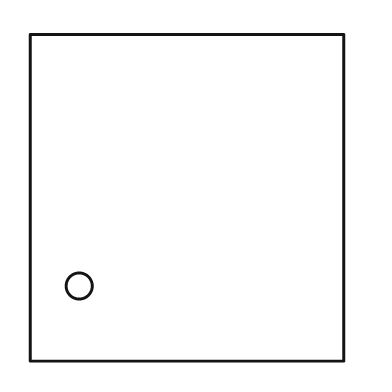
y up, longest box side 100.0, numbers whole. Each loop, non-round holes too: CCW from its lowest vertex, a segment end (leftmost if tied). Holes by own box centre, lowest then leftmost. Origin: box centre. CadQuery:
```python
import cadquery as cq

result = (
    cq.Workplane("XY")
    .moveTo(-48.0, -50.0)
    .lineTo(48.0, -50.0)
    .lineTo(48.0, 50.0)
    .lineTo(-48.0, 50.0)
    .close()
    .moveTo(-33.0, -27.0)
    .circle(4.0)
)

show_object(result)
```